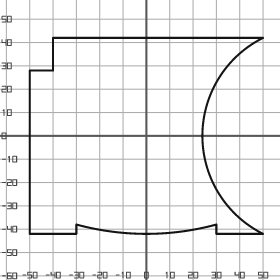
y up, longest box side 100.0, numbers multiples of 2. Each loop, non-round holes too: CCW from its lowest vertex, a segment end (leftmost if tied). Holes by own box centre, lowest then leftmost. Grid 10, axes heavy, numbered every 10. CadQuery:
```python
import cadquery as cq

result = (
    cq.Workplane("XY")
    .moveTo(-50.0, -42.0)
    .lineTo(-30.0, -42.0)
    .lineTo(-30.0, -38.0)
    .threePointArc((0.0, -42.0), (30.0, -38.0))
    .lineTo(30.0, -42.0)
    .lineTo(50.0, -42.0)
    .threePointArc((24.0, 0.0), (50.0, 42.0))
    .lineTo(-40.0, 42.0)
    .lineTo(-40.0, 28.0)
    .lineTo(-50.0, 28.0)
    .close()
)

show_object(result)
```